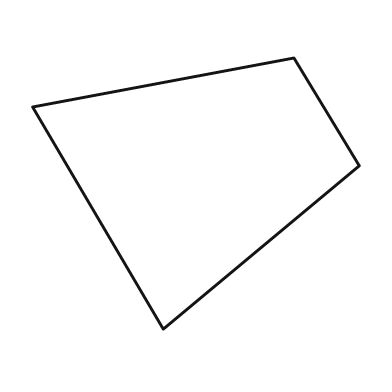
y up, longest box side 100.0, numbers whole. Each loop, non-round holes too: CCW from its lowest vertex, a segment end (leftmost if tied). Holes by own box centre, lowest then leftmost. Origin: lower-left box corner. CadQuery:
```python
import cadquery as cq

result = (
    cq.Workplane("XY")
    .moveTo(40.0, 0.0)
    .lineTo(100.0, 50.0)
    .lineTo(80.0, 83.0)
    .lineTo(0.0, 68.0)
    .close()
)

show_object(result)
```